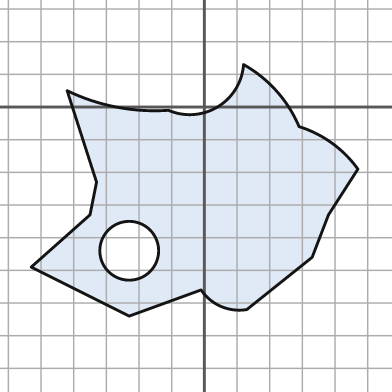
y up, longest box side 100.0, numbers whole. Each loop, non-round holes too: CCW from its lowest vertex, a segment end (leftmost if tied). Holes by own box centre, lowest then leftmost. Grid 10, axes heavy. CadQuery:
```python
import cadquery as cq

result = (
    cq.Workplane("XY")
    .moveTo(-23.0, -64.0)
    .lineTo(-1.0, -56.0)
    .threePointArc((5.0, -61.0), (13.0, -62.0))
    .lineTo(33.0, -46.0)
    .lineTo(38.0, -33.0)
    .lineTo(47.0, -19.0)
    .threePointArc((39.0, -11.0), (29.0, -6.0))
    .threePointArc((22.0, 5.0), (12.0, 13.0))
    .threePointArc((4.0, 0.0), (-11.0, -1.0))
    .threePointArc((-27.0, 0.0), (-42.0, 5.0))
    .lineTo(-33.0, -23.0)
    .lineTo(-35.0, -33.0)
    .lineTo(-53.0, -49.0)
    .close()
    .moveTo(-23.0, -44.0)
    .circle(9.0)
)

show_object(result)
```